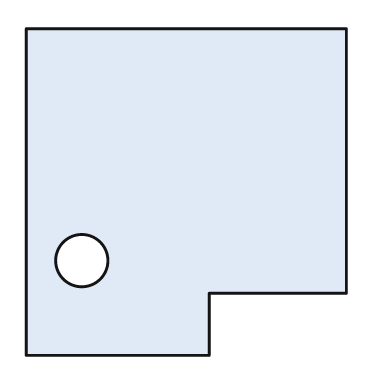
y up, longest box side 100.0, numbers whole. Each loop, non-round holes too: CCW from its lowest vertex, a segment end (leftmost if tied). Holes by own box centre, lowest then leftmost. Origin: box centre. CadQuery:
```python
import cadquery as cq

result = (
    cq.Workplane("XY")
    .moveTo(-49.0, -50.0)
    .lineTo(7.0, -50.0)
    .lineTo(7.0, -31.0)
    .lineTo(49.0, -31.0)
    .lineTo(49.0, 50.0)
    .lineTo(-49.0, 50.0)
    .close()
    .moveTo(-32.0, -21.0)
    .circle(8.0)
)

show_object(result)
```